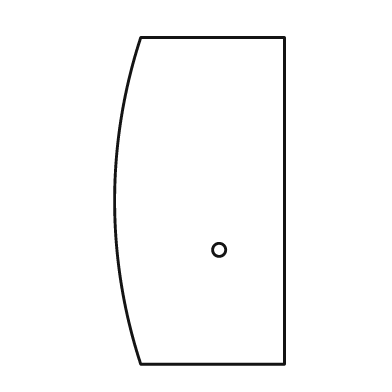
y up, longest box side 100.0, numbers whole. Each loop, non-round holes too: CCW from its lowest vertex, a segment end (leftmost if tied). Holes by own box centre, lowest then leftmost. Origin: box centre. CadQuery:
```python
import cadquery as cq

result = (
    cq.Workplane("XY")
    .moveTo(-18.0, -50.0)
    .lineTo(26.0, -50.0)
    .lineTo(26.0, 50.0)
    .lineTo(-18.0, 50.0)
    .threePointArc((-26.0, 0.0), (-18.0, -50.0))
    .close()
    .moveTo(6.0, -15.0)
    .circle(2.0)
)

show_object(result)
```